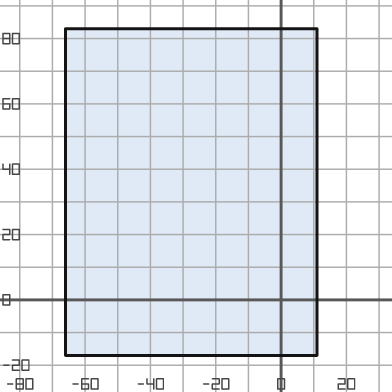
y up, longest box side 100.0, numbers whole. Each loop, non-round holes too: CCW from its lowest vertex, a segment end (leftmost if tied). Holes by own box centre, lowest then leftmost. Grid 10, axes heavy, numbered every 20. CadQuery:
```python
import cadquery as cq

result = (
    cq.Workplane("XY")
    .moveTo(-66.0, -17.0)
    .lineTo(11.0, -17.0)
    .lineTo(11.0, 83.0)
    .lineTo(-66.0, 83.0)
    .close()
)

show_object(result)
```